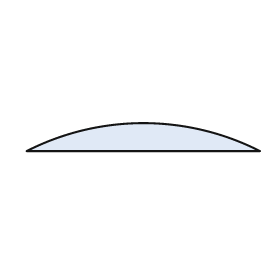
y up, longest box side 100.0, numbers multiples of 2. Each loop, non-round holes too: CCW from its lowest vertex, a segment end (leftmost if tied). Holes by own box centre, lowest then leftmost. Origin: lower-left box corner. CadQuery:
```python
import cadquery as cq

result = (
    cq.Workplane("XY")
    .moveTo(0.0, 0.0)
    .lineTo(100.0, 0.0)
    .threePointArc((50.0, 12.0), (0.0, 0.0))
    .close()
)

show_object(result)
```